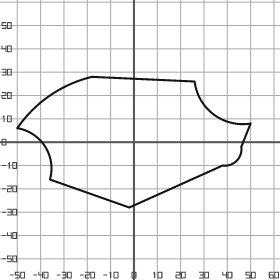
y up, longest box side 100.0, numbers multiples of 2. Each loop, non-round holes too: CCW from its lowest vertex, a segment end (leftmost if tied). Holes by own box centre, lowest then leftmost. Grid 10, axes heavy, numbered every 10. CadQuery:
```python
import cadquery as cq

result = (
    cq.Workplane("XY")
    .moveTo(-2.0, -28.0)
    .lineTo(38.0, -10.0)
    .threePointArc((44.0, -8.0), (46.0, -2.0))
    .lineTo(50.0, 8.0)
    .threePointArc((34.0, 12.0), (26.0, 26.0))
    .lineTo(-18.0, 28.0)
    .threePointArc((-36.0, 20.0), (-50.0, 6.0))
    .threePointArc((-38.0, -2.0), (-36.0, -16.0))
    .close()
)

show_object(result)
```